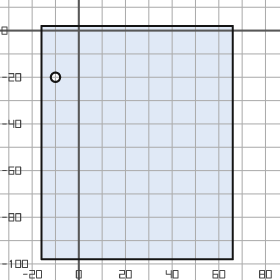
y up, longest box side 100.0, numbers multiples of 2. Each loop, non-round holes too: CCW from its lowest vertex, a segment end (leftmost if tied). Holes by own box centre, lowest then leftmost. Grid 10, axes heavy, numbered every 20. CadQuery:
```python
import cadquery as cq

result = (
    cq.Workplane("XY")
    .moveTo(-16.0, -98.0)
    .lineTo(66.0, -98.0)
    .lineTo(66.0, 2.0)
    .lineTo(-16.0, 2.0)
    .close()
    .moveTo(-10.0, -20.0)
    .circle(2.0)
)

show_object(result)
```